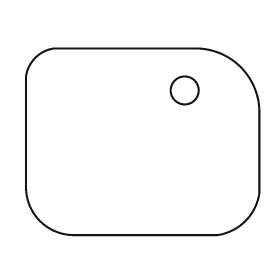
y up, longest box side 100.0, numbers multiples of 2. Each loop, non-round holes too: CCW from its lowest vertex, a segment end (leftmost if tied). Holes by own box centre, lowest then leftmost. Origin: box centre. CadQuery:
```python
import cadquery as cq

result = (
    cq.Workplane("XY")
    .moveTo(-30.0, -40.0)
    .lineTo(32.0, -40.0)
    .threePointArc((44.0, -34.0), (50.0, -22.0))
    .lineTo(50.0, 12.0)
    .threePointArc((42.0, 32.0), (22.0, 40.0))
    .lineTo(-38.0, 40.0)
    .threePointArc((-46.0, 36.0), (-50.0, 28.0))
    .lineTo(-50.0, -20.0)
    .threePointArc((-44.0, -34.0), (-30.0, -40.0))
    .close()
    .moveTo(18.0, 22.0)
    .circle(6.0)
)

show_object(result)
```